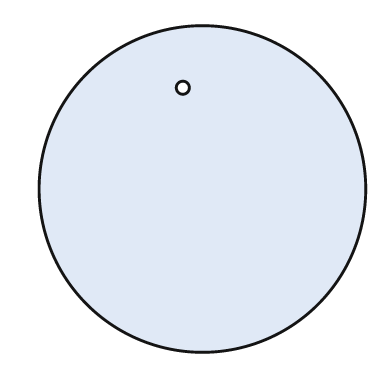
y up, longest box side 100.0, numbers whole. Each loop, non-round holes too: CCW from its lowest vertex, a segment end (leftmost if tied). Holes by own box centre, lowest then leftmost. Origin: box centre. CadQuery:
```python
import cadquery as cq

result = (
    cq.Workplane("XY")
    .moveTo(0.0, 0.0)
    .circle(50.0)
    .moveTo(-6.0, 31.0)
    .circle(2.0)
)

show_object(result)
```